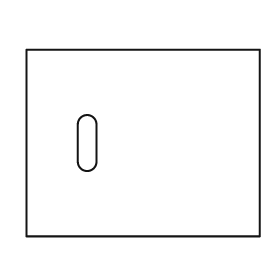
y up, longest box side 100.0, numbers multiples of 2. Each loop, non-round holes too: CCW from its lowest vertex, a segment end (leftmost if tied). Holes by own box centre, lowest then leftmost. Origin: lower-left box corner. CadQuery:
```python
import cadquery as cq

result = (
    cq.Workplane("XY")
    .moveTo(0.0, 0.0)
    .lineTo(100.0, 0.0)
    .lineTo(100.0, 80.0)
    .lineTo(0.0, 80.0)
    .close()
    .moveTo(22.0, 32.0)
    .threePointArc((26.0, 28.0), (30.0, 32.0))
    .lineTo(30.0, 48.0)
    .threePointArc((26.0, 52.0), (22.0, 48.0))
    .close()
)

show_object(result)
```